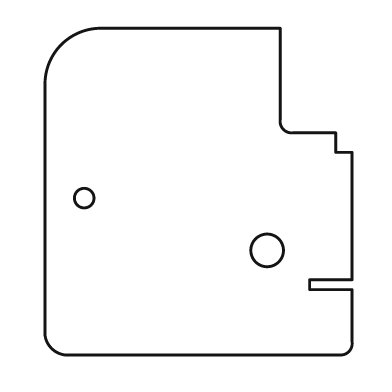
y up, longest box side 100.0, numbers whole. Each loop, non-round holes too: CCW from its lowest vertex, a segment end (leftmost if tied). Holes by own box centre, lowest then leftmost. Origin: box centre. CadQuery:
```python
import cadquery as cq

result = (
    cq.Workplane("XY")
    .moveTo(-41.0, -50.0)
    .lineTo(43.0, -50.0)
    .threePointArc((46.0, -49.0), (47.0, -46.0))
    .lineTo(47.0, -30.0)
    .lineTo(34.0, -30.0)
    .lineTo(34.0, -27.0)
    .lineTo(47.0, -27.0)
    .lineTo(47.0, 12.0)
    .lineTo(42.0, 12.0)
    .lineTo(42.0, 18.0)
    .lineTo(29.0, 18.0)
    .threePointArc((26.0, 19.0), (25.0, 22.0))
    .lineTo(25.0, 50.0)
    .lineTo(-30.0, 50.0)
    .threePointArc((-42.0, 45.0), (-47.0, 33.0))
    .lineTo(-47.0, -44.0)
    .threePointArc((-45.0, -48.0), (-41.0, -50.0))
    .close()
    .moveTo(21.0, -18.0)
    .circle(5.0)
    .moveTo(-35.0, -2.0)
    .circle(3.0)
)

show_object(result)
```